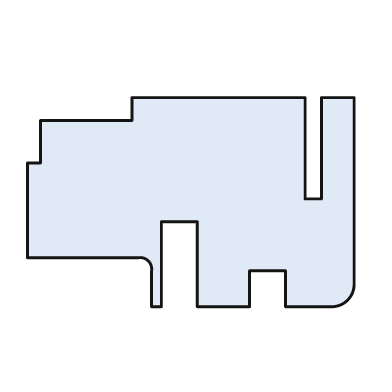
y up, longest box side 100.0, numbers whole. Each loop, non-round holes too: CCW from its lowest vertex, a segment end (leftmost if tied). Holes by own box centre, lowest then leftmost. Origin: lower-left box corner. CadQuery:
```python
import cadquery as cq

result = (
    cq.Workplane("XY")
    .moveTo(38.0, 0.0)
    .lineTo(41.0, 0.0)
    .lineTo(41.0, 26.0)
    .lineTo(52.0, 26.0)
    .lineTo(52.0, 0.0)
    .lineTo(68.0, 0.0)
    .lineTo(68.0, 11.0)
    .lineTo(79.0, 11.0)
    .lineTo(79.0, 0.0)
    .lineTo(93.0, 0.0)
    .threePointArc((98.0, 2.0), (100.0, 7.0))
    .lineTo(100.0, 64.0)
    .lineTo(90.0, 64.0)
    .lineTo(90.0, 33.0)
    .lineTo(85.0, 33.0)
    .lineTo(85.0, 64.0)
    .lineTo(32.0, 64.0)
    .lineTo(32.0, 57.0)
    .lineTo(4.0, 57.0)
    .lineTo(4.0, 44.0)
    .lineTo(0.0, 44.0)
    .lineTo(0.0, 15.0)
    .lineTo(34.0, 15.0)
    .threePointArc((37.0, 14.0), (38.0, 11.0))
    .close()
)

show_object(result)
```